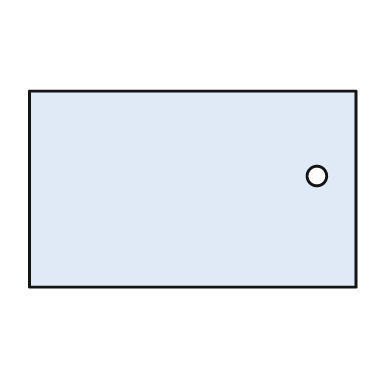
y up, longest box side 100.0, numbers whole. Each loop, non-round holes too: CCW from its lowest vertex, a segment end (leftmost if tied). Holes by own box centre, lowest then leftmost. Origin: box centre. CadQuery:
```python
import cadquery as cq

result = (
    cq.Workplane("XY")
    .moveTo(-50.0, -30.0)
    .lineTo(50.0, -30.0)
    .lineTo(50.0, 30.0)
    .lineTo(-50.0, 30.0)
    .close()
    .moveTo(38.0, 4.0)
    .circle(3.0)
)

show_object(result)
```